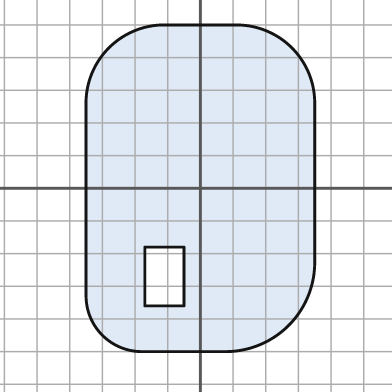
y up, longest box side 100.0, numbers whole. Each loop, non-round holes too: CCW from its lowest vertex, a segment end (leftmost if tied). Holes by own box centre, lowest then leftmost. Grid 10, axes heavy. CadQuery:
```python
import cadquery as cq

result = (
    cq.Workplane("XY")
    .moveTo(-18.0, -50.0)
    .lineTo(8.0, -50.0)
    .threePointArc((27.0, -42.0), (35.0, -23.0))
    .lineTo(35.0, 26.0)
    .threePointArc((28.0, 43.0), (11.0, 50.0))
    .lineTo(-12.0, 50.0)
    .threePointArc((-28.0, 43.0), (-35.0, 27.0))
    .lineTo(-35.0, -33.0)
    .threePointArc((-30.0, -45.0), (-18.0, -50.0))
    .close()
    .moveTo(-17.0, -36.0)
    .lineTo(-5.0, -36.0)
    .lineTo(-5.0, -18.0)
    .lineTo(-17.0, -18.0)
    .close()
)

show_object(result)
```